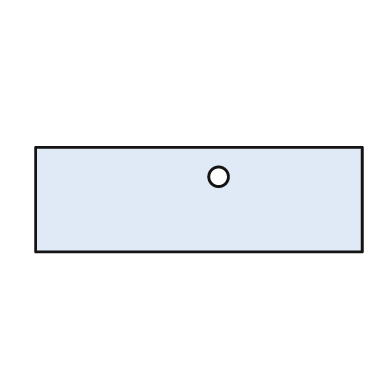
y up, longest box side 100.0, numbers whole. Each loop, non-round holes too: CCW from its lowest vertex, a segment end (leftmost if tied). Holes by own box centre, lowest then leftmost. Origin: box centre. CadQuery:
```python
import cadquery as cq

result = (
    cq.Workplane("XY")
    .moveTo(-50.0, -16.0)
    .lineTo(50.0, -16.0)
    .lineTo(50.0, 16.0)
    .lineTo(-50.0, 16.0)
    .close()
    .moveTo(6.0, 7.0)
    .circle(3.0)
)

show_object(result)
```